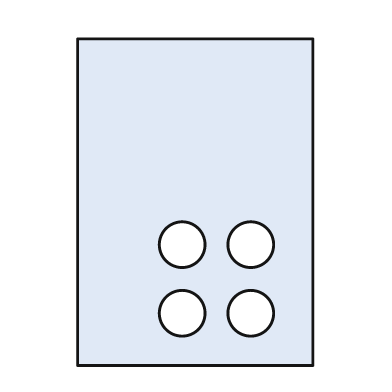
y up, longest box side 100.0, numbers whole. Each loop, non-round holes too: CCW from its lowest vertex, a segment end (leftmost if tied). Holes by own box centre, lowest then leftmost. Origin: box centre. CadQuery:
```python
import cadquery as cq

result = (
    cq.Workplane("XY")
    .moveTo(-36.0, -50.0)
    .lineTo(36.0, -50.0)
    .lineTo(36.0, 50.0)
    .lineTo(-36.0, 50.0)
    .close()
    .moveTo(-4.0, -34.0)
    .circle(7.0)
    .moveTo(17.0, -34.0)
    .circle(7.0)
    .moveTo(-4.0, -13.0)
    .circle(7.0)
    .moveTo(17.0, -13.0)
    .circle(7.0)
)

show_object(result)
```